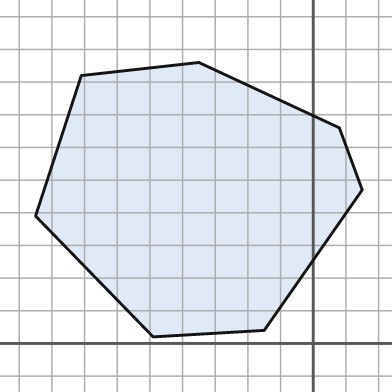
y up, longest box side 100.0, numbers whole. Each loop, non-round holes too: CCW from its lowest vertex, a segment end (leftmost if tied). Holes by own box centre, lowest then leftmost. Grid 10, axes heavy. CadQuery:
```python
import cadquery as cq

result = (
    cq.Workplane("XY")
    .moveTo(-49.0, 2.0)
    .lineTo(-15.0, 4.0)
    .lineTo(15.0, 47.0)
    .lineTo(8.0, 66.0)
    .lineTo(-35.0, 86.0)
    .lineTo(-71.0, 82.0)
    .lineTo(-85.0, 39.0)
    .close()
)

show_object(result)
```